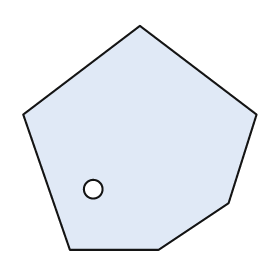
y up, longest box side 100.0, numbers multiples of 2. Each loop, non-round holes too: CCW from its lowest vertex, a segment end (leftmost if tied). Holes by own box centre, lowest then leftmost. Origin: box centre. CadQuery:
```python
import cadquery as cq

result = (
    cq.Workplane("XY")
    .moveTo(-30.0, -48.0)
    .lineTo(8.0, -48.0)
    .lineTo(38.0, -28.0)
    .lineTo(50.0, 10.0)
    .lineTo(0.0, 48.0)
    .lineTo(-50.0, 10.0)
    .close()
    .moveTo(-20.0, -22.0)
    .circle(4.0)
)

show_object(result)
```